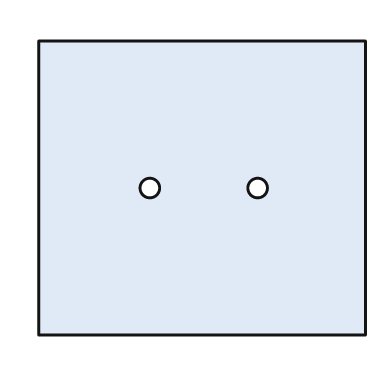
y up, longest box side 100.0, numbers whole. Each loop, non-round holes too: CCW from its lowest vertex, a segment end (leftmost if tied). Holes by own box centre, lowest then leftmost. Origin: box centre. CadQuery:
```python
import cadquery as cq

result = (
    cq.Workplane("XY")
    .moveTo(-50.0, -45.0)
    .lineTo(50.0, -45.0)
    .lineTo(50.0, 45.0)
    .lineTo(-50.0, 45.0)
    .close()
    .moveTo(-16.0, 0.0)
    .circle(3.0)
    .moveTo(17.0, 0.0)
    .circle(3.0)
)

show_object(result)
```